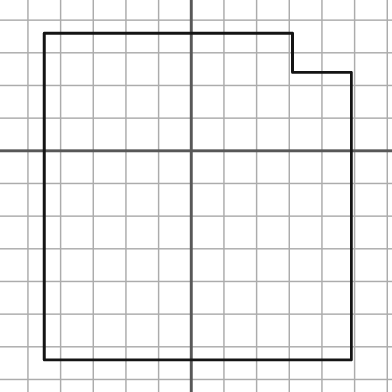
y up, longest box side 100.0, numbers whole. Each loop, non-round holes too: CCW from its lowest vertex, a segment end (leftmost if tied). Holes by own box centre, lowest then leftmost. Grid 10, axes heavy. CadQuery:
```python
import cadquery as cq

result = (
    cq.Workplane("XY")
    .moveTo(-45.0, -64.0)
    .lineTo(49.0, -64.0)
    .lineTo(49.0, 24.0)
    .lineTo(31.0, 24.0)
    .lineTo(31.0, 36.0)
    .lineTo(-45.0, 36.0)
    .close()
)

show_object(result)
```